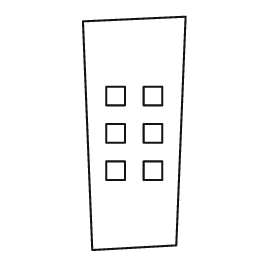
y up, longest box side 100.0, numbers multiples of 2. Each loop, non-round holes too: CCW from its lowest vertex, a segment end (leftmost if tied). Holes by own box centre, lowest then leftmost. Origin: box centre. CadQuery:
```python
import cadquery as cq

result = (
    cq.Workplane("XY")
    .moveTo(-18.0, -50.0)
    .lineTo(18.0, -48.0)
    .lineTo(22.0, 50.0)
    .lineTo(-22.0, 48.0)
    .close()
    .moveTo(-12.0, -20.0)
    .lineTo(-4.0, -20.0)
    .lineTo(-4.0, -12.0)
    .lineTo(-12.0, -12.0)
    .close()
    .moveTo(4.0, -20.0)
    .lineTo(12.0, -20.0)
    .lineTo(12.0, -12.0)
    .lineTo(4.0, -12.0)
    .close()
    .moveTo(-12.0, -4.0)
    .lineTo(-4.0, -4.0)
    .lineTo(-4.0, 4.0)
    .lineTo(-12.0, 4.0)
    .close()
    .moveTo(4.0, -4.0)
    .lineTo(12.0, -4.0)
    .lineTo(12.0, 4.0)
    .lineTo(4.0, 4.0)
    .close()
    .moveTo(-12.0, 12.0)
    .lineTo(-4.0, 12.0)
    .lineTo(-4.0, 20.0)
    .lineTo(-12.0, 20.0)
    .close()
    .moveTo(4.0, 12.0)
    .lineTo(12.0, 12.0)
    .lineTo(12.0, 20.0)
    .lineTo(4.0, 20.0)
    .close()
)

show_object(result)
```